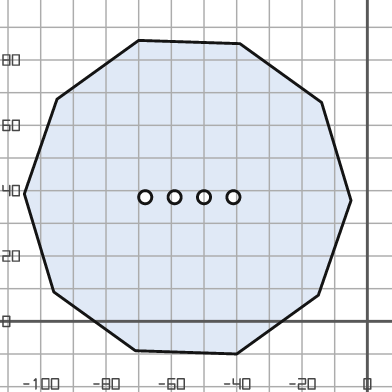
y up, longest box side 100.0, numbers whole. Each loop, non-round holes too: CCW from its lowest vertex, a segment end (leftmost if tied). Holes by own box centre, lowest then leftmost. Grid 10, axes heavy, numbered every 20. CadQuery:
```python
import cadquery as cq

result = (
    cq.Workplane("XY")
    .moveTo(-40.0, -10.0)
    .lineTo(-15.0, 8.0)
    .lineTo(-5.0, 37.0)
    .lineTo(-14.0, 67.0)
    .lineTo(-39.0, 85.0)
    .lineTo(-70.0, 86.0)
    .lineTo(-95.0, 68.0)
    .lineTo(-105.0, 39.0)
    .lineTo(-96.0, 9.0)
    .lineTo(-71.0, -9.0)
    .close()
    .moveTo(-68.0, 38.0)
    .circle(2.0)
    .moveTo(-59.0, 38.0)
    .circle(2.0)
    .moveTo(-50.0, 38.0)
    .circle(2.0)
    .moveTo(-41.0, 38.0)
    .circle(2.0)
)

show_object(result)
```